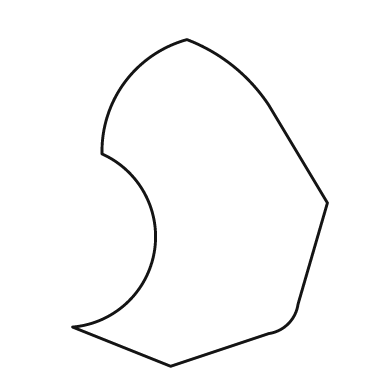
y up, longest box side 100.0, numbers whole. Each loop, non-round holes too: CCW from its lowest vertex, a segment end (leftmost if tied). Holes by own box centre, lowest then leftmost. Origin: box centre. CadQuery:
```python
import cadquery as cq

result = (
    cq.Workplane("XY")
    .moveTo(-9.0, -50.0)
    .lineTo(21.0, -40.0)
    .threePointArc((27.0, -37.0), (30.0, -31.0))
    .lineTo(39.0, 0.0)
    .lineTo(21.0, 30.0)
    .threePointArc((10.0, 42.0), (-4.0, 50.0))
    .threePointArc((-23.0, 37.0), (-30.0, 15.0))
    .threePointArc((-14.0, -15.0), (-39.0, -38.0))
    .close()
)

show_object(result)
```